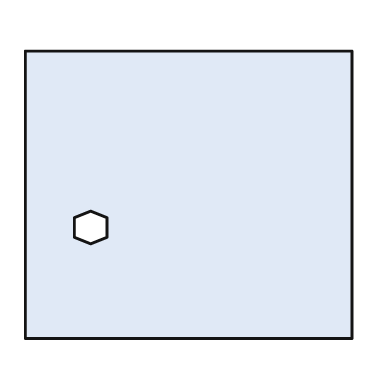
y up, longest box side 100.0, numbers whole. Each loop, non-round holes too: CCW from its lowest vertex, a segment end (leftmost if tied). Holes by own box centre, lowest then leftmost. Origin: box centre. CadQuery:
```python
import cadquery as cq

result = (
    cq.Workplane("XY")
    .moveTo(-50.0, -44.0)
    .lineTo(50.0, -44.0)
    .lineTo(50.0, 44.0)
    .lineTo(-50.0, 44.0)
    .close()
    .moveTo(-30.0, -15.0)
    .lineTo(-25.0, -13.0)
    .lineTo(-25.0, -7.0)
    .lineTo(-30.0, -5.0)
    .lineTo(-35.0, -7.0)
    .lineTo(-35.0, -13.0)
    .close()
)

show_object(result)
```